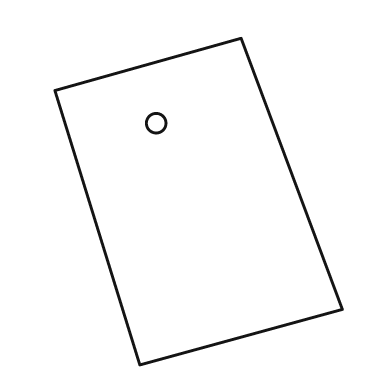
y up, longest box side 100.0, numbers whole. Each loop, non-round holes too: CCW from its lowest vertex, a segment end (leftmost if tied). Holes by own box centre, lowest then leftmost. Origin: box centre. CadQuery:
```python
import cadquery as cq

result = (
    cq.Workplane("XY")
    .moveTo(-18.0, -50.0)
    .lineTo(44.0, -33.0)
    .lineTo(13.0, 50.0)
    .lineTo(-44.0, 34.0)
    .close()
    .moveTo(-13.0, 24.0)
    .circle(3.0)
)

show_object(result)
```